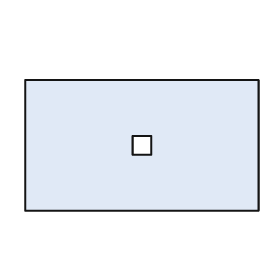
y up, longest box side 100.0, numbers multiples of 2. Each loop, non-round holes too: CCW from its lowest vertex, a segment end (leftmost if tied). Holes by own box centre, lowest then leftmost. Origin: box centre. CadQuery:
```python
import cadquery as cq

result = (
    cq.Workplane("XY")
    .moveTo(-50.0, -28.0)
    .lineTo(50.0, -28.0)
    .lineTo(50.0, 28.0)
    .lineTo(-50.0, 28.0)
    .close()
    .moveTo(-4.0, -4.0)
    .lineTo(4.0, -4.0)
    .lineTo(4.0, 4.0)
    .lineTo(-4.0, 4.0)
    .close()
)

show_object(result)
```